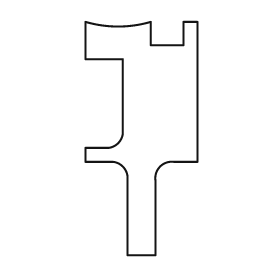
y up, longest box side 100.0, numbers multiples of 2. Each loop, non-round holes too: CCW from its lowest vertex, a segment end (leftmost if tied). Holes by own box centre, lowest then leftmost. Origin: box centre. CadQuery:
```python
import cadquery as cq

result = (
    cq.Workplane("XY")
    .moveTo(-6.0, -50.0)
    .lineTo(6.0, -50.0)
    .lineTo(6.0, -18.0)
    .threePointArc((8.0, -12.0), (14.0, -10.0))
    .lineTo(24.0, -10.0)
    .lineTo(24.0, 50.0)
    .lineTo(18.0, 50.0)
    .lineTo(18.0, 40.0)
    .lineTo(4.0, 40.0)
    .lineTo(4.0, 50.0)
    .threePointArc((-10.0, 48.0), (-24.0, 50.0))
    .lineTo(-24.0, 34.0)
    .lineTo(-8.0, 34.0)
    .lineTo(-8.0, 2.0)
    .threePointArc((-10.0, -2.0), (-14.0, -4.0))
    .lineTo(-24.0, -4.0)
    .lineTo(-24.0, -10.0)
    .lineTo(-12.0, -10.0)
    .threePointArc((-8.0, -12.0), (-6.0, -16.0))
    .close()
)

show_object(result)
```